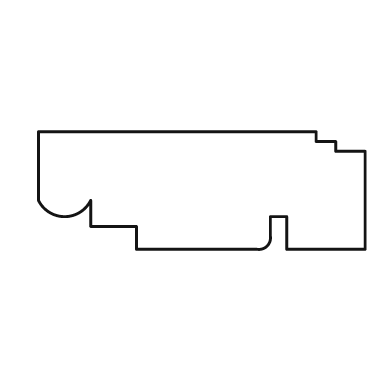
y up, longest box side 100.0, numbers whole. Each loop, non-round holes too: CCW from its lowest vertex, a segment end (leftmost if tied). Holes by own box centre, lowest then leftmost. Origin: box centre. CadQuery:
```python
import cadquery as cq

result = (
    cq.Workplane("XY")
    .moveTo(-20.0, -18.0)
    .lineTo(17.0, -18.0)
    .threePointArc((20.0, -17.0), (21.0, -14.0))
    .lineTo(21.0, -8.0)
    .lineTo(26.0, -8.0)
    .lineTo(26.0, -18.0)
    .lineTo(50.0, -18.0)
    .lineTo(50.0, 12.0)
    .lineTo(41.0, 12.0)
    .lineTo(41.0, 15.0)
    .lineTo(35.0, 15.0)
    .lineTo(35.0, 18.0)
    .lineTo(-50.0, 18.0)
    .lineTo(-50.0, -3.0)
    .threePointArc((-42.0, -8.0), (-34.0, -3.0))
    .lineTo(-34.0, -11.0)
    .lineTo(-20.0, -11.0)
    .close()
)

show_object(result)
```